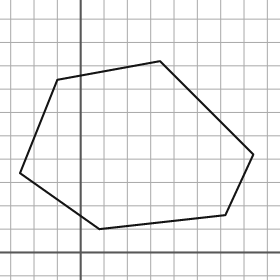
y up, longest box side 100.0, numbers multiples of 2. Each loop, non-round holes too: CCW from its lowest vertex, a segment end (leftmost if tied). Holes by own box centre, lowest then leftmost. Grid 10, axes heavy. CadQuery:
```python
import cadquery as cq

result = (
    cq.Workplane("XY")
    .moveTo(8.0, 10.0)
    .lineTo(62.0, 16.0)
    .lineTo(74.0, 42.0)
    .lineTo(34.0, 82.0)
    .lineTo(-10.0, 74.0)
    .lineTo(-26.0, 34.0)
    .close()
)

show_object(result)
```